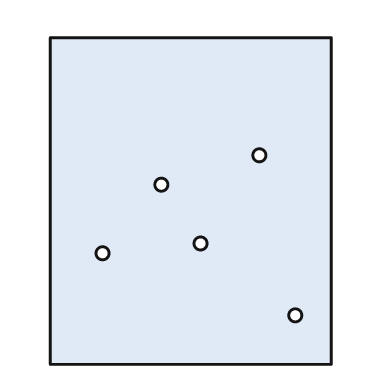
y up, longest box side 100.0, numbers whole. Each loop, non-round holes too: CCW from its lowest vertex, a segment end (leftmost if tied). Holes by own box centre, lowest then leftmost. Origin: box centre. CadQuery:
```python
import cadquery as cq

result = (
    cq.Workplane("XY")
    .moveTo(-43.0, -50.0)
    .lineTo(43.0, -50.0)
    .lineTo(43.0, 50.0)
    .lineTo(-43.0, 50.0)
    .close()
    .moveTo(32.0, -35.0)
    .circle(2.0)
    .moveTo(-27.0, -16.0)
    .circle(2.0)
    .moveTo(3.0, -13.0)
    .circle(2.0)
    .moveTo(-9.0, 5.0)
    .circle(2.0)
    .moveTo(21.0, 14.0)
    .circle(2.0)
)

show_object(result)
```